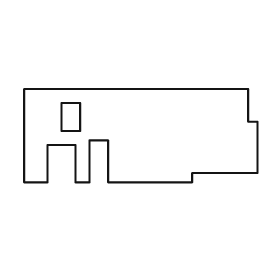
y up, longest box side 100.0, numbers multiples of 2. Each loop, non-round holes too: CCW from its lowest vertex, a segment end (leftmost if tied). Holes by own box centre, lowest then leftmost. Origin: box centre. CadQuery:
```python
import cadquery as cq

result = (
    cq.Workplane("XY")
    .moveTo(-50.0, -20.0)
    .lineTo(-40.0, -20.0)
    .lineTo(-40.0, -4.0)
    .lineTo(-28.0, -4.0)
    .lineTo(-28.0, -20.0)
    .lineTo(-22.0, -20.0)
    .lineTo(-22.0, -2.0)
    .lineTo(-14.0, -2.0)
    .lineTo(-14.0, -20.0)
    .lineTo(22.0, -20.0)
    .lineTo(22.0, -16.0)
    .lineTo(50.0, -16.0)
    .lineTo(50.0, 6.0)
    .lineTo(46.0, 6.0)
    .lineTo(46.0, 20.0)
    .lineTo(-50.0, 20.0)
    .close()
    .moveTo(-34.0, 2.0)
    .lineTo(-26.0, 2.0)
    .lineTo(-26.0, 14.0)
    .lineTo(-34.0, 14.0)
    .close()
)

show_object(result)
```